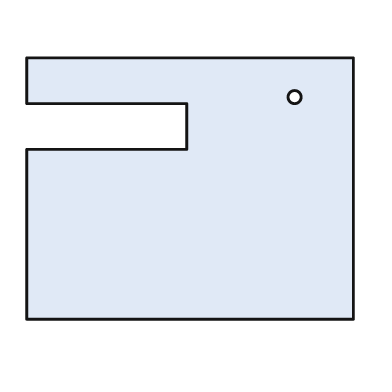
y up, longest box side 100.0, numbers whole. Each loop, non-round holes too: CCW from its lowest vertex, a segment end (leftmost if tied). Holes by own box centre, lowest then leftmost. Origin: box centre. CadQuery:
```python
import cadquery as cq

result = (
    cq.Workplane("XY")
    .moveTo(-50.0, -40.0)
    .lineTo(50.0, -40.0)
    .lineTo(50.0, 40.0)
    .lineTo(-50.0, 40.0)
    .lineTo(-50.0, 26.0)
    .lineTo(-1.0, 26.0)
    .lineTo(-1.0, 12.0)
    .lineTo(-50.0, 12.0)
    .close()
    .moveTo(32.0, 28.0)
    .circle(2.0)
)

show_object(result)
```